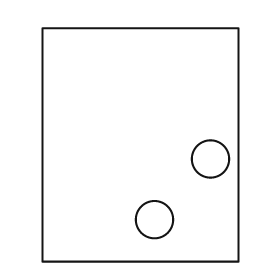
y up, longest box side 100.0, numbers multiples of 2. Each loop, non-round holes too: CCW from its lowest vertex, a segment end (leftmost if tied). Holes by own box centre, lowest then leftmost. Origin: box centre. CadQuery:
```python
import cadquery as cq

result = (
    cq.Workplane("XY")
    .moveTo(-42.0, -50.0)
    .lineTo(42.0, -50.0)
    .lineTo(42.0, 50.0)
    .lineTo(-42.0, 50.0)
    .close()
    .moveTo(6.0, -32.0)
    .circle(8.0)
    .moveTo(30.0, -6.0)
    .circle(8.0)
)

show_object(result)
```